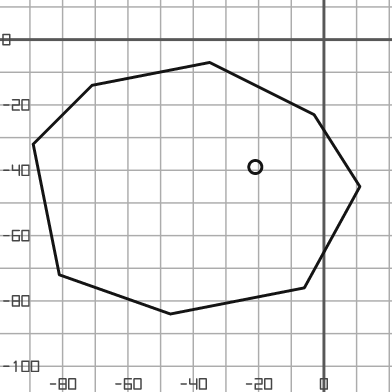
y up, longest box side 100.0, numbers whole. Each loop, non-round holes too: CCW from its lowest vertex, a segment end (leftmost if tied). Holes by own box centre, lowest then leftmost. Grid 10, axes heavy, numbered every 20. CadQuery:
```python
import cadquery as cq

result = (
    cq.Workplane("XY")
    .moveTo(-47.0, -84.0)
    .lineTo(-6.0, -76.0)
    .lineTo(11.0, -45.0)
    .lineTo(-3.0, -23.0)
    .lineTo(-35.0, -7.0)
    .lineTo(-71.0, -14.0)
    .lineTo(-89.0, -32.0)
    .lineTo(-81.0, -72.0)
    .close()
    .moveTo(-21.0, -39.0)
    .circle(2.0)
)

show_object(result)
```